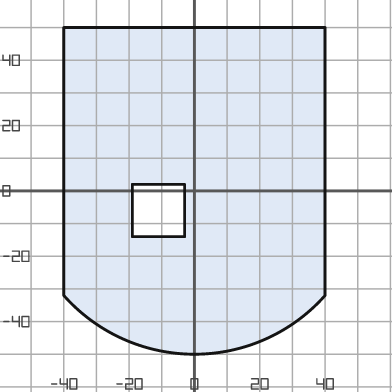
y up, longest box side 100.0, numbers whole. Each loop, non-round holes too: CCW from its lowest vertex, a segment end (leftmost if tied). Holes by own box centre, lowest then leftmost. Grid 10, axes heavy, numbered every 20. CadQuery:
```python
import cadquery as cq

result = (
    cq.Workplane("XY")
    .moveTo(-40.0, -32.0)
    .threePointArc((0.0, -50.0), (40.0, -32.0))
    .lineTo(40.0, 50.0)
    .lineTo(-40.0, 50.0)
    .close()
    .moveTo(-19.0, -14.0)
    .lineTo(-3.0, -14.0)
    .lineTo(-3.0, 2.0)
    .lineTo(-19.0, 2.0)
    .close()
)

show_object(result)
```